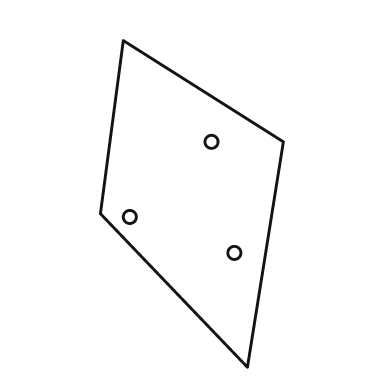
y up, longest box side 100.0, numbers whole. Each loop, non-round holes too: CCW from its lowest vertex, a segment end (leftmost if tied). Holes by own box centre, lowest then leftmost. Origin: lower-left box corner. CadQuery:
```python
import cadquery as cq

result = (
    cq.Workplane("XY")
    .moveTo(45.0, 0.0)
    .lineTo(56.0, 69.0)
    .lineTo(7.0, 100.0)
    .lineTo(0.0, 47.0)
    .close()
    .moveTo(41.0, 35.0)
    .circle(2.0)
    .moveTo(9.0, 46.0)
    .circle(2.0)
    .moveTo(34.0, 69.0)
    .circle(2.0)
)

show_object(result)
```